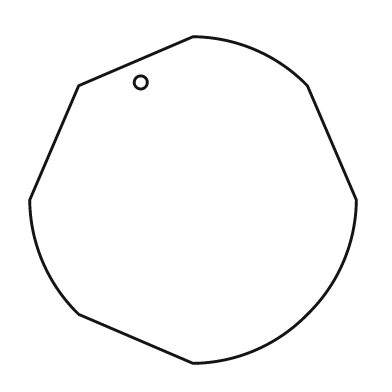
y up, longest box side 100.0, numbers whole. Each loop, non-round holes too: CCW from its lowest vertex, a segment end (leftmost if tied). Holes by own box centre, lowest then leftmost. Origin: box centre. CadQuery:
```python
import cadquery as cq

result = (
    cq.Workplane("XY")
    .moveTo(0.0, -50.0)
    .threePointArc((19.0, -46.0), (35.0, -35.0))
    .threePointArc((46.0, -19.0), (50.0, 0.0))
    .lineTo(35.0, 35.0)
    .threePointArc((19.0, 46.0), (0.0, 50.0))
    .lineTo(-35.0, 35.0)
    .lineTo(-50.0, 0.0)
    .threePointArc((-46.0, -19.0), (-35.0, -35.0))
    .close()
    .moveTo(-16.0, 36.0)
    .circle(2.0)
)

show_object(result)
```